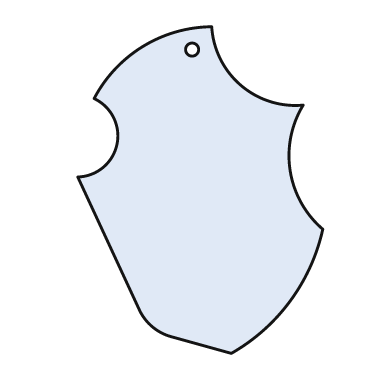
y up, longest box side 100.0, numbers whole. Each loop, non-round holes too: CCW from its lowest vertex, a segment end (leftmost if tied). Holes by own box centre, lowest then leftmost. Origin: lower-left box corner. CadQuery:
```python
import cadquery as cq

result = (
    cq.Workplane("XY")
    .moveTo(47.0, 0.0)
    .threePointArc((65.0, 16.0), (75.0, 38.0))
    .threePointArc((65.0, 56.0), (69.0, 76.0))
    .threePointArc((50.0, 82.0), (41.0, 100.0))
    .threePointArc((20.0, 94.0), (5.0, 78.0))
    .threePointArc((12.0, 64.0), (0.0, 54.0))
    .lineTo(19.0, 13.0)
    .threePointArc((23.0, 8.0), (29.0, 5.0))
    .close()
    .moveTo(35.0, 93.0)
    .circle(2.0)
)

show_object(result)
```